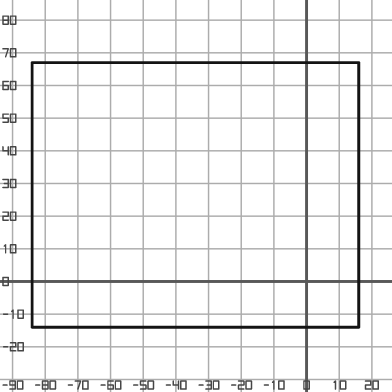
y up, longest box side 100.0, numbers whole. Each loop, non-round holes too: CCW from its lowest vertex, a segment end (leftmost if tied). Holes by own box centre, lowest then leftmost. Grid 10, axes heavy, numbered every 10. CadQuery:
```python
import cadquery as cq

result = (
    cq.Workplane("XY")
    .moveTo(-84.0, -14.0)
    .lineTo(16.0, -14.0)
    .lineTo(16.0, 67.0)
    .lineTo(-84.0, 67.0)
    .close()
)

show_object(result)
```